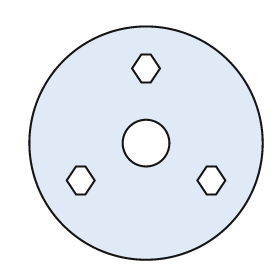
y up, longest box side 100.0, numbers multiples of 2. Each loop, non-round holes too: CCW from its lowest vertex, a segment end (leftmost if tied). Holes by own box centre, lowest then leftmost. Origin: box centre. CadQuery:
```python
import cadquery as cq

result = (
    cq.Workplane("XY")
    .moveTo(0.0, 0.0)
    .circle(50.0)
    .moveTo(-30.0, -22.0)
    .lineTo(-26.0, -22.0)
    .lineTo(-22.0, -16.0)
    .lineTo(-26.0, -10.0)
    .lineTo(-30.0, -10.0)
    .lineTo(-34.0, -16.0)
    .close()
    .moveTo(26.0, -22.0)
    .lineTo(30.0, -22.0)
    .lineTo(34.0, -16.0)
    .lineTo(30.0, -10.0)
    .lineTo(26.0, -10.0)
    .lineTo(22.0, -16.0)
    .close()
    .moveTo(0.0, 0.0)
    .circle(10.0)
    .moveTo(-2.0, 26.0)
    .lineTo(2.0, 26.0)
    .lineTo(6.0, 32.0)
    .lineTo(2.0, 38.0)
    .lineTo(-2.0, 38.0)
    .lineTo(-6.0, 32.0)
    .close()
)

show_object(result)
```